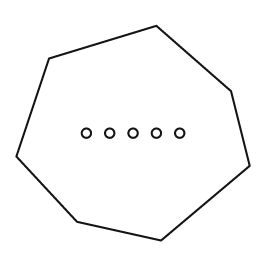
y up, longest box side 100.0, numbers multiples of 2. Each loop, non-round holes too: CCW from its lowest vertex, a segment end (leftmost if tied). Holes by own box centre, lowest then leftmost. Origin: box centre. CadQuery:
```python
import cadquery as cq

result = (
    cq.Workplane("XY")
    .moveTo(12.0, -46.0)
    .lineTo(50.0, -14.0)
    .lineTo(42.0, 18.0)
    .lineTo(10.0, 46.0)
    .lineTo(-36.0, 32.0)
    .lineTo(-50.0, -10.0)
    .lineTo(-24.0, -38.0)
    .close()
    .moveTo(-20.0, 0.0)
    .circle(2.0)
    .moveTo(-10.0, 0.0)
    .circle(2.0)
    .moveTo(0.0, 0.0)
    .circle(2.0)
    .moveTo(10.0, 0.0)
    .circle(2.0)
    .moveTo(20.0, 0.0)
    .circle(2.0)
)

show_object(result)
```